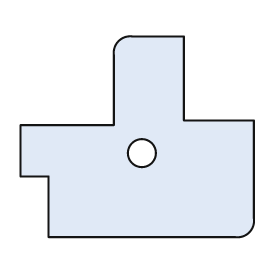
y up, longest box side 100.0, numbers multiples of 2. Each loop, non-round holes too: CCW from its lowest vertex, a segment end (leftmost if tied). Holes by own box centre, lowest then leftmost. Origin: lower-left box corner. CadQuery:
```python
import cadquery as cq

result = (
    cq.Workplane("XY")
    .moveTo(12.0, 0.0)
    .lineTo(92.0, 0.0)
    .threePointArc((98.0, 2.0), (100.0, 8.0))
    .lineTo(100.0, 50.0)
    .lineTo(70.0, 50.0)
    .lineTo(70.0, 86.0)
    .lineTo(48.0, 86.0)
    .threePointArc((42.0, 84.0), (40.0, 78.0))
    .lineTo(40.0, 48.0)
    .lineTo(0.0, 48.0)
    .lineTo(0.0, 26.0)
    .lineTo(12.0, 26.0)
    .close()
    .moveTo(52.0, 36.0)
    .circle(6.0)
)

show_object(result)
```